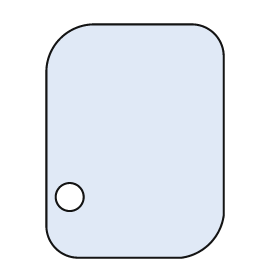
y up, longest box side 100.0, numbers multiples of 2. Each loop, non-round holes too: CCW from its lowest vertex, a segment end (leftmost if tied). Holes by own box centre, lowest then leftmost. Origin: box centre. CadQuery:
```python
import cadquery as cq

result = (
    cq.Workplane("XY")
    .moveTo(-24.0, -50.0)
    .lineTo(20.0, -50.0)
    .threePointArc((32.0, -44.0), (38.0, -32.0))
    .lineTo(38.0, 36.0)
    .threePointArc((34.0, 46.0), (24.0, 50.0))
    .lineTo(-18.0, 50.0)
    .threePointArc((-32.0, 44.0), (-38.0, 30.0))
    .lineTo(-38.0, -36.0)
    .threePointArc((-34.0, -46.0), (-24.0, -50.0))
    .close()
    .moveTo(-28.0, -24.0)
    .circle(6.0)
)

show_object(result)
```